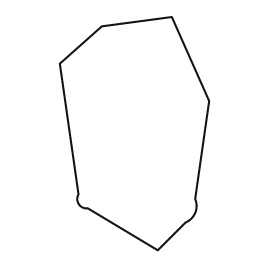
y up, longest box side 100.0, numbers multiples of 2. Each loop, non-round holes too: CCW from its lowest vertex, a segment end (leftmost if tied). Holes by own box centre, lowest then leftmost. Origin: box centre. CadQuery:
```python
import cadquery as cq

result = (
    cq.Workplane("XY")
    .moveTo(10.0, -50.0)
    .lineTo(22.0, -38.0)
    .threePointArc((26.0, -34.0), (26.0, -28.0))
    .lineTo(32.0, 14.0)
    .lineTo(16.0, 50.0)
    .lineTo(-14.0, 46.0)
    .lineTo(-32.0, 30.0)
    .lineTo(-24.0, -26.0)
    .threePointArc((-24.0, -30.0), (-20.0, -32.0))
    .close()
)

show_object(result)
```